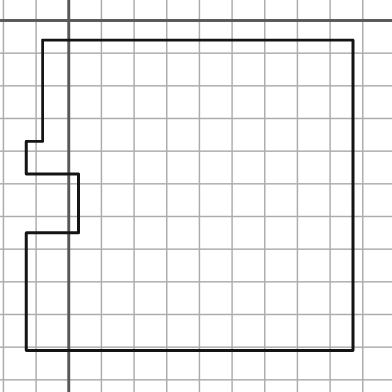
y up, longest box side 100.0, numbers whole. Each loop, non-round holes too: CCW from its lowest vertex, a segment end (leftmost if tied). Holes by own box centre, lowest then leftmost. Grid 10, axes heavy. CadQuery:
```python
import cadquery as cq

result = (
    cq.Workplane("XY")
    .moveTo(-13.0, -101.0)
    .lineTo(87.0, -101.0)
    .lineTo(87.0, -6.0)
    .lineTo(-8.0, -6.0)
    .lineTo(-8.0, -37.0)
    .lineTo(-13.0, -37.0)
    .lineTo(-13.0, -47.0)
    .lineTo(3.0, -47.0)
    .lineTo(3.0, -65.0)
    .lineTo(-13.0, -65.0)
    .close()
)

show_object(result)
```